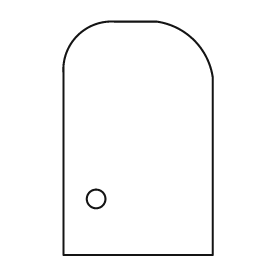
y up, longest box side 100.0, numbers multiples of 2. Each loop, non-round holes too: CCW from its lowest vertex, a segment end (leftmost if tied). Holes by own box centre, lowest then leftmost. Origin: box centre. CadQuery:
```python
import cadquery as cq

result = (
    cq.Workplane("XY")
    .moveTo(-32.0, -50.0)
    .lineTo(32.0, -50.0)
    .lineTo(32.0, 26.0)
    .threePointArc((24.0, 42.0), (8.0, 50.0))
    .lineTo(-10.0, 50.0)
    .threePointArc((-26.0, 44.0), (-32.0, 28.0))
    .close()
    .moveTo(-18.0, -26.0)
    .circle(4.0)
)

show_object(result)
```